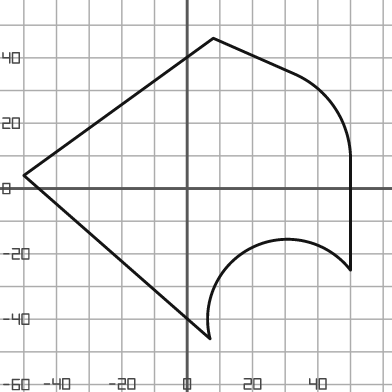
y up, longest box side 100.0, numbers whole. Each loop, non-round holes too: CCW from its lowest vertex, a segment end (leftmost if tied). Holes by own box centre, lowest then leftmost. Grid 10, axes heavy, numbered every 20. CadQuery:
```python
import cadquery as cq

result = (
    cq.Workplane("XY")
    .moveTo(7.0, -46.0)
    .threePointArc((20.0, -18.0), (50.0, -25.0))
    .lineTo(50.0, 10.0)
    .threePointArc((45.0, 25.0), (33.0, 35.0))
    .lineTo(8.0, 46.0)
    .lineTo(-50.0, 4.0)
    .close()
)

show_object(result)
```